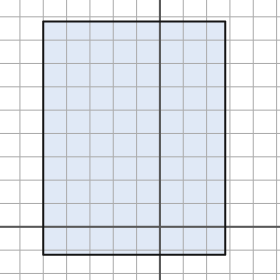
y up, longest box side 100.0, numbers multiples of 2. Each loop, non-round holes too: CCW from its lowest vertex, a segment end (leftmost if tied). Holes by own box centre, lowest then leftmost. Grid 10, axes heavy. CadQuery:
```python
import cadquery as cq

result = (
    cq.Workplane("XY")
    .moveTo(-50.0, -12.0)
    .lineTo(28.0, -12.0)
    .lineTo(28.0, 88.0)
    .lineTo(-50.0, 88.0)
    .close()
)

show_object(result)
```